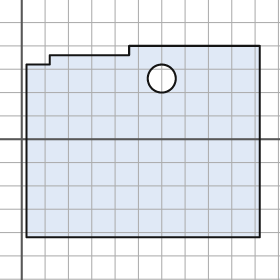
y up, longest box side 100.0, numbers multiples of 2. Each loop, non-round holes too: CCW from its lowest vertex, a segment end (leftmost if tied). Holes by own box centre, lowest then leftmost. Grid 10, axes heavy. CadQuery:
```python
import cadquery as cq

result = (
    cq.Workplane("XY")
    .moveTo(2.0, -42.0)
    .lineTo(102.0, -42.0)
    .lineTo(102.0, 40.0)
    .lineTo(46.0, 40.0)
    .lineTo(46.0, 36.0)
    .lineTo(12.0, 36.0)
    .lineTo(12.0, 32.0)
    .lineTo(2.0, 32.0)
    .close()
    .moveTo(60.0, 26.0)
    .circle(6.0)
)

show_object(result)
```